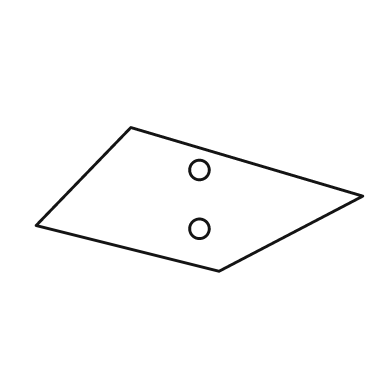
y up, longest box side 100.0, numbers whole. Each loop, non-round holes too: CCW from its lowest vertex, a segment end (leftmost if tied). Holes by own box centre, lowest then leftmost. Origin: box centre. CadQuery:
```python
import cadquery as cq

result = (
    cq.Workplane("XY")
    .moveTo(6.0, -22.0)
    .lineTo(50.0, 1.0)
    .lineTo(-21.0, 22.0)
    .lineTo(-50.0, -8.0)
    .close()
    .moveTo(0.0, -9.0)
    .circle(3.0)
    .moveTo(0.0, 9.0)
    .circle(3.0)
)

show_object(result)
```